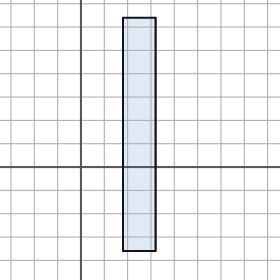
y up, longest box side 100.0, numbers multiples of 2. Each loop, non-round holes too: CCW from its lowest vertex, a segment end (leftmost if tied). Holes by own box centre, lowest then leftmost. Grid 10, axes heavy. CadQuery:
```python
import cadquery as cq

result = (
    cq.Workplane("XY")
    .moveTo(18.0, -36.0)
    .lineTo(32.0, -36.0)
    .lineTo(32.0, 64.0)
    .lineTo(18.0, 64.0)
    .close()
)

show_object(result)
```